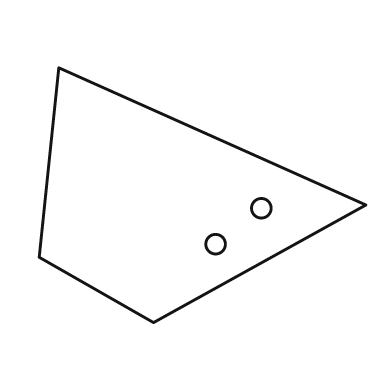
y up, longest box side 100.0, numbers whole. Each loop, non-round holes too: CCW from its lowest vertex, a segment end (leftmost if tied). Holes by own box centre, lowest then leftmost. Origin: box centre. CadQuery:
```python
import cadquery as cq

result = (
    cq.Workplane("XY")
    .moveTo(-15.0, -39.0)
    .lineTo(50.0, -3.0)
    .lineTo(-44.0, 39.0)
    .lineTo(-50.0, -19.0)
    .close()
    .moveTo(4.0, -15.0)
    .circle(3.0)
    .moveTo(18.0, -4.0)
    .circle(3.0)
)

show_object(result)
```